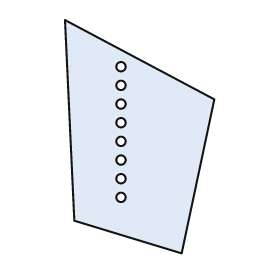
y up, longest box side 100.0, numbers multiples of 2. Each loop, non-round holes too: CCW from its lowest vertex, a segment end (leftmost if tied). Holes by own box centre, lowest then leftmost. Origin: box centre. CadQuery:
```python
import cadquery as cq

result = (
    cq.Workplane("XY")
    .moveTo(18.0, -50.0)
    .lineTo(32.0, 16.0)
    .lineTo(-32.0, 50.0)
    .lineTo(-28.0, -36.0)
    .close()
    .moveTo(-8.0, -26.0)
    .circle(2.0)
    .moveTo(-8.0, -18.0)
    .circle(2.0)
    .moveTo(-8.0, -10.0)
    .circle(2.0)
    .moveTo(-8.0, -2.0)
    .circle(2.0)
    .moveTo(-8.0, 6.0)
    .circle(2.0)
    .moveTo(-8.0, 14.0)
    .circle(2.0)
    .moveTo(-8.0, 22.0)
    .circle(2.0)
    .moveTo(-8.0, 30.0)
    .circle(2.0)
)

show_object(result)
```